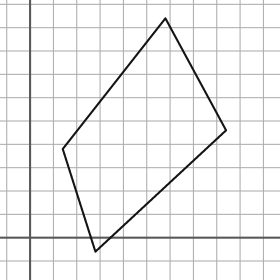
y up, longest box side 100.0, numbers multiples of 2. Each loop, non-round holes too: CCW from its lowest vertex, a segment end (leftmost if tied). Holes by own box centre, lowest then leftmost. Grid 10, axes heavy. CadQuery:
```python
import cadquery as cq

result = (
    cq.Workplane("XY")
    .moveTo(28.0, -6.0)
    .lineTo(84.0, 46.0)
    .lineTo(58.0, 94.0)
    .lineTo(14.0, 38.0)
    .close()
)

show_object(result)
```